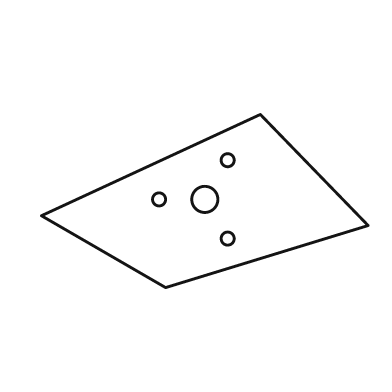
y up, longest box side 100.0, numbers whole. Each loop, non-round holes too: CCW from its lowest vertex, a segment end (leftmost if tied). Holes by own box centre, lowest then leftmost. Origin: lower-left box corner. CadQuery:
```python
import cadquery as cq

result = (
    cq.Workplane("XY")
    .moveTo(38.0, 0.0)
    .lineTo(100.0, 19.0)
    .lineTo(67.0, 53.0)
    .lineTo(0.0, 22.0)
    .close()
    .moveTo(57.0, 15.0)
    .circle(2.0)
    .moveTo(36.0, 27.0)
    .circle(2.0)
    .moveTo(50.0, 27.0)
    .circle(4.0)
    .moveTo(57.0, 39.0)
    .circle(2.0)
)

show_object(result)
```